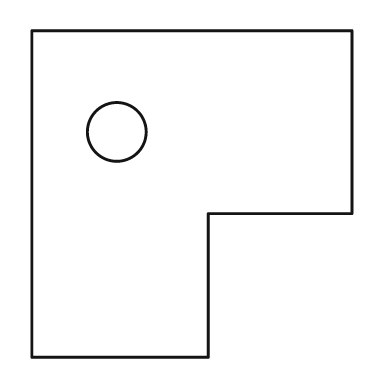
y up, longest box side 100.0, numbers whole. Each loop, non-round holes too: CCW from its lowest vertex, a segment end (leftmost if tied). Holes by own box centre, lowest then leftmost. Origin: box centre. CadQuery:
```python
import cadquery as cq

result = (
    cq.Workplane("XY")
    .moveTo(-49.0, -50.0)
    .lineTo(5.0, -50.0)
    .lineTo(5.0, -6.0)
    .lineTo(49.0, -6.0)
    .lineTo(49.0, 50.0)
    .lineTo(-49.0, 50.0)
    .close()
    .moveTo(-23.0, 19.0)
    .circle(9.0)
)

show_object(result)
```